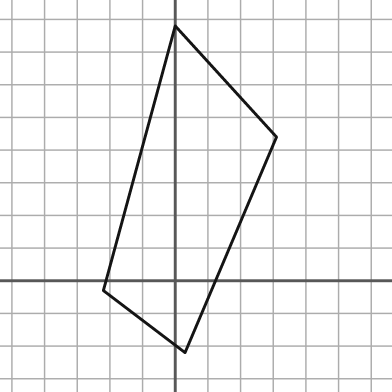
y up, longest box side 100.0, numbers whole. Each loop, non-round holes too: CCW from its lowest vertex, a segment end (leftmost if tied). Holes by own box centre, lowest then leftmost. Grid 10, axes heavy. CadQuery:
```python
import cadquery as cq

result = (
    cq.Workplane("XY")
    .moveTo(3.0, -22.0)
    .lineTo(31.0, 44.0)
    .lineTo(0.0, 78.0)
    .lineTo(-22.0, -3.0)
    .close()
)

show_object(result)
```